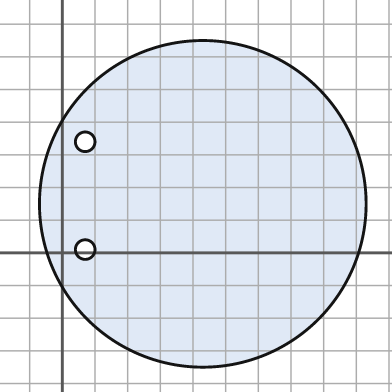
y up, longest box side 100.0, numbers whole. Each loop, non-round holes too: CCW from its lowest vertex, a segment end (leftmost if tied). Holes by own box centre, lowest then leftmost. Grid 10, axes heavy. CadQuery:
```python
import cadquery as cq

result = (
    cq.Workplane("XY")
    .moveTo(43.0, 15.0)
    .circle(50.0)
    .moveTo(7.0, 1.0)
    .circle(3.0)
    .moveTo(7.0, 34.0)
    .circle(3.0)
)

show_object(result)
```